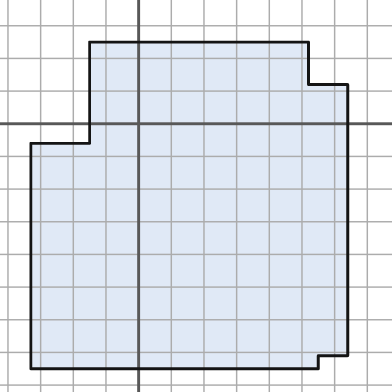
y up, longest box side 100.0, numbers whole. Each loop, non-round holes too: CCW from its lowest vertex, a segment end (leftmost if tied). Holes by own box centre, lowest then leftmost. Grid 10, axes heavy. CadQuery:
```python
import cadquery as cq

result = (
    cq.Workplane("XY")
    .moveTo(-33.0, -75.0)
    .lineTo(55.0, -75.0)
    .lineTo(55.0, -71.0)
    .lineTo(64.0, -71.0)
    .lineTo(64.0, 12.0)
    .lineTo(52.0, 12.0)
    .lineTo(52.0, 25.0)
    .lineTo(-15.0, 25.0)
    .lineTo(-15.0, -6.0)
    .lineTo(-33.0, -6.0)
    .close()
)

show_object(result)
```